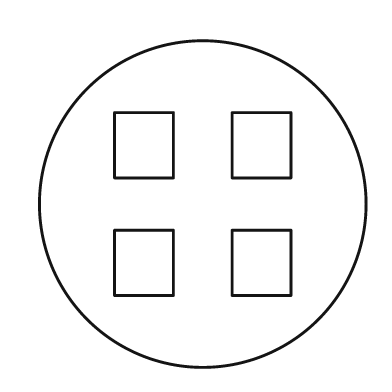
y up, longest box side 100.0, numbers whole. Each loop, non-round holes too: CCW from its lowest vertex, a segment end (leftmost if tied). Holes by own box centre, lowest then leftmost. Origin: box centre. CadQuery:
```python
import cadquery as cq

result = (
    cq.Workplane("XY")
    .moveTo(0.0, 0.0)
    .circle(50.0)
    .moveTo(-27.0, -28.0)
    .lineTo(-9.0, -28.0)
    .lineTo(-9.0, -8.0)
    .lineTo(-27.0, -8.0)
    .close()
    .moveTo(9.0, -28.0)
    .lineTo(27.0, -28.0)
    .lineTo(27.0, -8.0)
    .lineTo(9.0, -8.0)
    .close()
    .moveTo(-27.0, 8.0)
    .lineTo(-9.0, 8.0)
    .lineTo(-9.0, 28.0)
    .lineTo(-27.0, 28.0)
    .close()
    .moveTo(9.0, 8.0)
    .lineTo(27.0, 8.0)
    .lineTo(27.0, 28.0)
    .lineTo(9.0, 28.0)
    .close()
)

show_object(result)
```